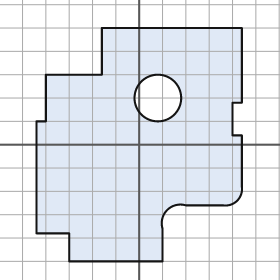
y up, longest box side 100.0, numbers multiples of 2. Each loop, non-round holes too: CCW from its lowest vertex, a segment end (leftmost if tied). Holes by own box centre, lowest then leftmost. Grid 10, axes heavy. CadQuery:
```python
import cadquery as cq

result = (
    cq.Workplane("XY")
    .moveTo(-30.0, -50.0)
    .lineTo(10.0, -50.0)
    .lineTo(10.0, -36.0)
    .threePointArc((12.0, -28.0), (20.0, -26.0))
    .lineTo(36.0, -26.0)
    .threePointArc((42.0, -24.0), (44.0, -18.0))
    .lineTo(44.0, 4.0)
    .lineTo(40.0, 4.0)
    .lineTo(40.0, 18.0)
    .lineTo(44.0, 18.0)
    .lineTo(44.0, 50.0)
    .lineTo(-16.0, 50.0)
    .lineTo(-16.0, 30.0)
    .lineTo(-40.0, 30.0)
    .lineTo(-40.0, 10.0)
    .lineTo(-44.0, 10.0)
    .lineTo(-44.0, -38.0)
    .lineTo(-30.0, -38.0)
    .close()
    .moveTo(8.0, 20.0)
    .circle(10.0)
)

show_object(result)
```